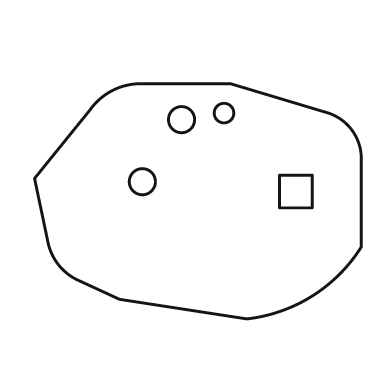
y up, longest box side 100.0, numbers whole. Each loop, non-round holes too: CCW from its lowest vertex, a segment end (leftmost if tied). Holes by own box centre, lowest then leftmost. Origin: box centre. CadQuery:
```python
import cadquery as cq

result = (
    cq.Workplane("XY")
    .moveTo(15.0, -36.0)
    .threePointArc((35.0, -29.0), (50.0, -14.0))
    .lineTo(50.0, 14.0)
    .threePointArc((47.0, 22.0), (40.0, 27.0))
    .lineTo(10.0, 36.0)
    .lineTo(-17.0, 36.0)
    .threePointArc((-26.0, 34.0), (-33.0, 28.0))
    .lineTo(-50.0, 7.0)
    .lineTo(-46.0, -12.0)
    .threePointArc((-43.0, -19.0), (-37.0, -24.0))
    .lineTo(-24.0, -30.0)
    .close()
    .moveTo(25.0, -2.0)
    .lineTo(35.0, -2.0)
    .lineTo(35.0, 8.0)
    .lineTo(25.0, 8.0)
    .close()
    .moveTo(-17.0, 6.0)
    .circle(4.0)
    .moveTo(-5.0, 25.0)
    .circle(4.0)
    .moveTo(8.0, 27.0)
    .circle(3.0)
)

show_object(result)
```